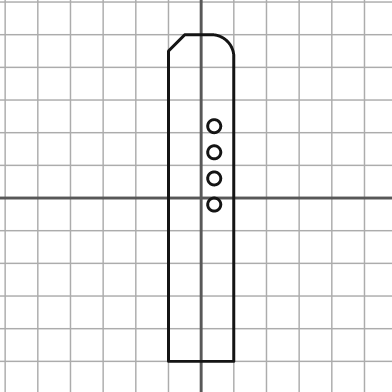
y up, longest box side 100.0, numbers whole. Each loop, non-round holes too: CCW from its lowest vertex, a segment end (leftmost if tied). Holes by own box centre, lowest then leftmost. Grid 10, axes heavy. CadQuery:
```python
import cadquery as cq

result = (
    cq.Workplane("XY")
    .moveTo(-10.0, -50.0)
    .lineTo(10.0, -50.0)
    .lineTo(10.0, 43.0)
    .threePointArc((8.0, 48.0), (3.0, 50.0))
    .lineTo(-5.0, 50.0)
    .lineTo(-10.0, 45.0)
    .close()
    .moveTo(4.0, -2.0)
    .circle(2.0)
    .moveTo(4.0, 6.0)
    .circle(2.0)
    .moveTo(4.0, 14.0)
    .circle(2.0)
    .moveTo(4.0, 22.0)
    .circle(2.0)
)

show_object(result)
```